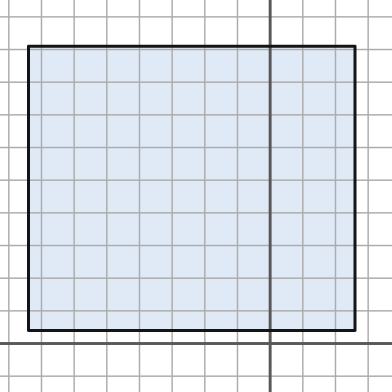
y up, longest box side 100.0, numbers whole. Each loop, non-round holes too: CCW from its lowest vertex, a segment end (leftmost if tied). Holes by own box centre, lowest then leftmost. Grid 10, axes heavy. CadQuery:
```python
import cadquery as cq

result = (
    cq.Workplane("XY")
    .moveTo(-74.0, 4.0)
    .lineTo(26.0, 4.0)
    .lineTo(26.0, 91.0)
    .lineTo(-74.0, 91.0)
    .close()
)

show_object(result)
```